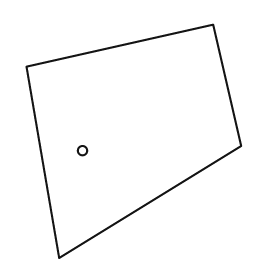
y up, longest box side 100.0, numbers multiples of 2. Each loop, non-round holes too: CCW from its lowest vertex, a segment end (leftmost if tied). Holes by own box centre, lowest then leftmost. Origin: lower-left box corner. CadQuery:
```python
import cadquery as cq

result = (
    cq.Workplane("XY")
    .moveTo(14.0, 0.0)
    .lineTo(92.0, 48.0)
    .lineTo(80.0, 100.0)
    .lineTo(0.0, 82.0)
    .close()
    .moveTo(24.0, 46.0)
    .circle(2.0)
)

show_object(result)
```